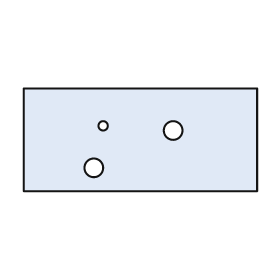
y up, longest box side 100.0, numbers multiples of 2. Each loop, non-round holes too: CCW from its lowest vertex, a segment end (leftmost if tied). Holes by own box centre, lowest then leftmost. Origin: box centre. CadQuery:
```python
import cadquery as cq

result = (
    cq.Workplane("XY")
    .moveTo(-50.0, -22.0)
    .lineTo(50.0, -22.0)
    .lineTo(50.0, 22.0)
    .lineTo(-50.0, 22.0)
    .close()
    .moveTo(-20.0, -12.0)
    .circle(4.0)
    .moveTo(14.0, 4.0)
    .circle(4.0)
    .moveTo(-16.0, 6.0)
    .circle(2.0)
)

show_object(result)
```